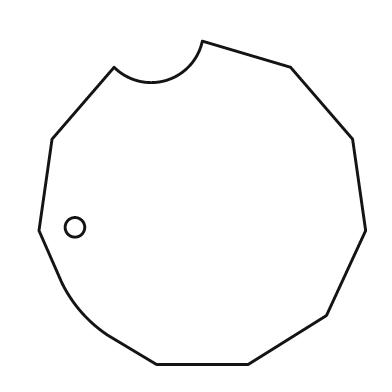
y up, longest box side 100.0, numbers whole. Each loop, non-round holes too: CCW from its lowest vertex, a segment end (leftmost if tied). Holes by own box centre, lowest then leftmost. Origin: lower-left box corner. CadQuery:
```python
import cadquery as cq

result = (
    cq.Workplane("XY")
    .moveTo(36.0, 0.0)
    .lineTo(64.0, 0.0)
    .lineTo(88.0, 15.0)
    .lineTo(100.0, 41.0)
    .lineTo(96.0, 69.0)
    .lineTo(77.0, 91.0)
    .lineTo(50.0, 99.0)
    .threePointArc((39.0, 87.0), (23.0, 91.0))
    .lineTo(4.0, 69.0)
    .lineTo(0.0, 41.0)
    .lineTo(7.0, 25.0)
    .threePointArc((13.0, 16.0), (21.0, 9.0))
    .close()
    .moveTo(11.0, 42.0)
    .circle(3.0)
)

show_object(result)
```